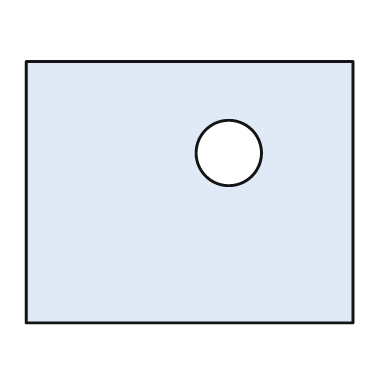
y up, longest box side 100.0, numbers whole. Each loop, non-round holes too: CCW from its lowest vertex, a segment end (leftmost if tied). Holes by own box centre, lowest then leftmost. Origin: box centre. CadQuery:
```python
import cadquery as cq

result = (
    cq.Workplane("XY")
    .moveTo(-50.0, -40.0)
    .lineTo(50.0, -40.0)
    .lineTo(50.0, 40.0)
    .lineTo(-50.0, 40.0)
    .close()
    .moveTo(12.0, 12.0)
    .circle(10.0)
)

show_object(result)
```